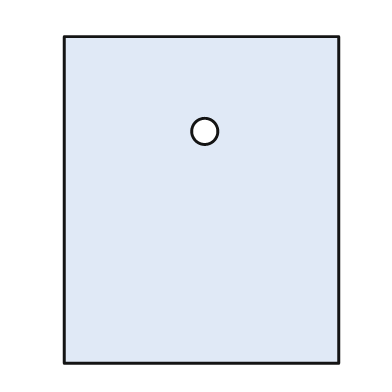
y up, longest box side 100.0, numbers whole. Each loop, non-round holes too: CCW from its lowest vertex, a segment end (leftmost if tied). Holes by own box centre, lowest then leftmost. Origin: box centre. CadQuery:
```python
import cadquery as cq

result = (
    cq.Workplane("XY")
    .moveTo(-42.0, -50.0)
    .lineTo(42.0, -50.0)
    .lineTo(42.0, 50.0)
    .lineTo(-42.0, 50.0)
    .close()
    .moveTo(1.0, 21.0)
    .circle(4.0)
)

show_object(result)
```